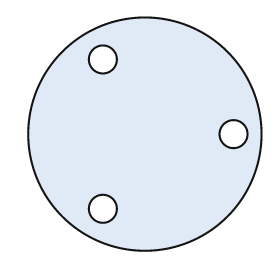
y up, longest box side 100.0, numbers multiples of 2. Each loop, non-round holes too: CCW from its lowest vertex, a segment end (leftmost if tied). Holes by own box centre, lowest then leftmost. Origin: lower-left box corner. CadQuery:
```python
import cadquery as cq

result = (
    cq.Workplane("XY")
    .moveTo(50.0, 50.0)
    .circle(50.0)
    .moveTo(32.0, 18.0)
    .circle(6.0)
    .moveTo(88.0, 50.0)
    .circle(6.0)
    .moveTo(32.0, 82.0)
    .circle(6.0)
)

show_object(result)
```